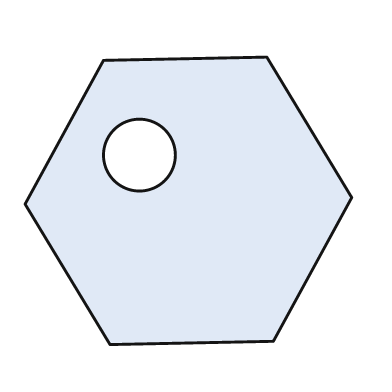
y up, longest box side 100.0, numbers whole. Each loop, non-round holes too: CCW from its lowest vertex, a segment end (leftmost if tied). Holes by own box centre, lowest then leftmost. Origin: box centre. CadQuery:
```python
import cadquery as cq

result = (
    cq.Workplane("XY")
    .moveTo(-24.0, -44.0)
    .lineTo(26.0, -43.0)
    .lineTo(50.0, 1.0)
    .lineTo(24.0, 44.0)
    .lineTo(-26.0, 43.0)
    .lineTo(-50.0, -1.0)
    .close()
    .moveTo(-15.0, 14.0)
    .circle(11.0)
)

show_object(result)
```